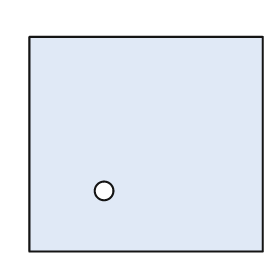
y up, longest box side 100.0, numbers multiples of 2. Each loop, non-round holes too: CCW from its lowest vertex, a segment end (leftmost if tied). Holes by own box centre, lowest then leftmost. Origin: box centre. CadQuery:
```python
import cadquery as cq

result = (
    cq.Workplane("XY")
    .moveTo(-50.0, -46.0)
    .lineTo(50.0, -46.0)
    .lineTo(50.0, 46.0)
    .lineTo(-50.0, 46.0)
    .close()
    .moveTo(-18.0, -20.0)
    .circle(4.0)
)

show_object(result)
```